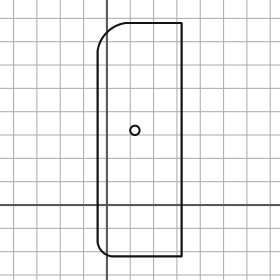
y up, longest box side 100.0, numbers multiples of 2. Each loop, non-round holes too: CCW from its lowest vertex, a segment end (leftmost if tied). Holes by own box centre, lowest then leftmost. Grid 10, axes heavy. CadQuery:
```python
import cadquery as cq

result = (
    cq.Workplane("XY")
    .moveTo(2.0, -22.0)
    .lineTo(32.0, -22.0)
    .lineTo(32.0, 78.0)
    .lineTo(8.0, 78.0)
    .threePointArc((0.0, 74.0), (-4.0, 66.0))
    .lineTo(-4.0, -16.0)
    .threePointArc((-2.0, -20.0), (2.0, -22.0))
    .close()
    .moveTo(12.0, 32.0)
    .circle(2.0)
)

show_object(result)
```